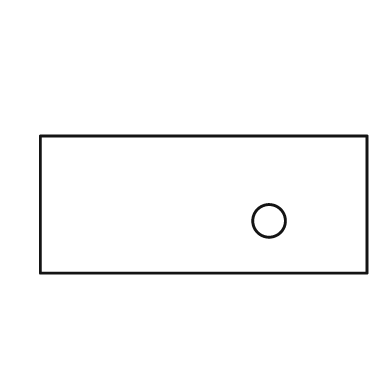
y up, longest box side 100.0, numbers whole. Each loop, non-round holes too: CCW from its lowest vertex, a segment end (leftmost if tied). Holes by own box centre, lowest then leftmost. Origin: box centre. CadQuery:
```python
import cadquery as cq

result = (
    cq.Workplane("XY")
    .moveTo(-50.0, -21.0)
    .lineTo(50.0, -21.0)
    .lineTo(50.0, 21.0)
    .lineTo(-50.0, 21.0)
    .close()
    .moveTo(20.0, -5.0)
    .circle(5.0)
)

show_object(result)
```